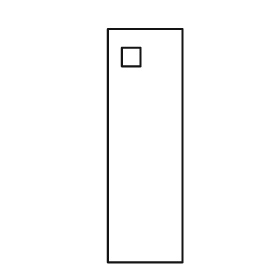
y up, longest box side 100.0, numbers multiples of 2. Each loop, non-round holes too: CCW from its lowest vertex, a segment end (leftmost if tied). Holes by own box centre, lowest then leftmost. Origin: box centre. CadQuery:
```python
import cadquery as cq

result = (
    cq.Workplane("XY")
    .moveTo(-16.0, -50.0)
    .lineTo(16.0, -50.0)
    .lineTo(16.0, 50.0)
    .lineTo(-16.0, 50.0)
    .close()
    .moveTo(-10.0, 34.0)
    .lineTo(-2.0, 34.0)
    .lineTo(-2.0, 42.0)
    .lineTo(-10.0, 42.0)
    .close()
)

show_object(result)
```